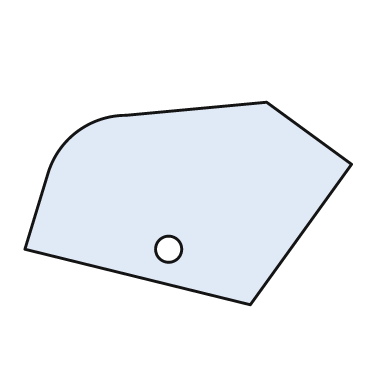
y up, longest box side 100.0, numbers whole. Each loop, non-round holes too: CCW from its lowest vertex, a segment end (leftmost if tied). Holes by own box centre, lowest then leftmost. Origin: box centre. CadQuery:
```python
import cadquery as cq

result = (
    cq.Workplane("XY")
    .moveTo(19.0, -31.0)
    .lineTo(50.0, 12.0)
    .lineTo(24.0, 31.0)
    .lineTo(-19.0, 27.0)
    .threePointArc((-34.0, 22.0), (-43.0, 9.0))
    .lineTo(-50.0, -14.0)
    .close()
    .moveTo(-6.0, -14.0)
    .circle(4.0)
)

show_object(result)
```